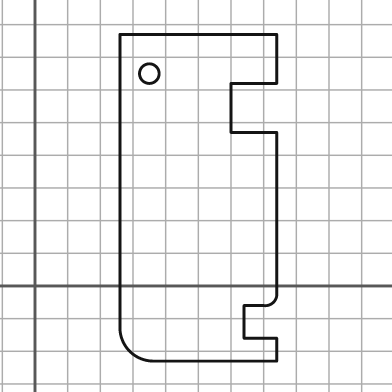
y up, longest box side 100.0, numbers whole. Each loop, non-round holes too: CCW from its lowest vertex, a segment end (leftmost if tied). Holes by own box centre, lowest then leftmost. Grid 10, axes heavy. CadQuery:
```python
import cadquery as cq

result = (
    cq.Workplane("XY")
    .moveTo(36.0, -23.0)
    .lineTo(74.0, -23.0)
    .lineTo(74.0, -16.0)
    .lineTo(64.0, -16.0)
    .lineTo(64.0, -6.0)
    .lineTo(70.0, -6.0)
    .threePointArc((73.0, -5.0), (74.0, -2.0))
    .lineTo(74.0, 47.0)
    .lineTo(60.0, 47.0)
    .lineTo(60.0, 62.0)
    .lineTo(74.0, 62.0)
    .lineTo(74.0, 77.0)
    .lineTo(26.0, 77.0)
    .lineTo(26.0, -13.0)
    .threePointArc((29.0, -20.0), (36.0, -23.0))
    .close()
    .moveTo(35.0, 65.0)
    .circle(3.0)
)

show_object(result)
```